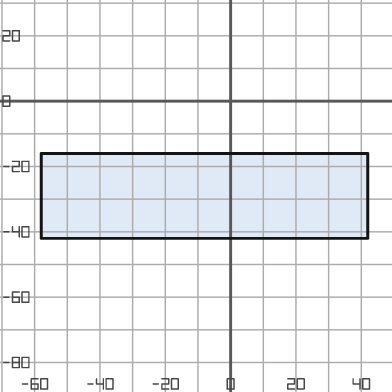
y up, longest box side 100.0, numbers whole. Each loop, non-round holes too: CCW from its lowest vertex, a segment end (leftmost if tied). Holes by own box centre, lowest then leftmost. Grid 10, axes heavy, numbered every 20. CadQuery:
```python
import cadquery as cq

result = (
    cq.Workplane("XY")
    .moveTo(-58.0, -42.0)
    .lineTo(42.0, -42.0)
    .lineTo(42.0, -16.0)
    .lineTo(-58.0, -16.0)
    .close()
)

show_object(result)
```